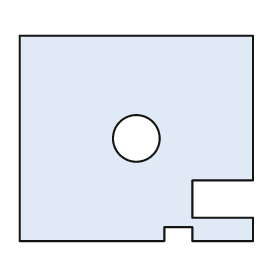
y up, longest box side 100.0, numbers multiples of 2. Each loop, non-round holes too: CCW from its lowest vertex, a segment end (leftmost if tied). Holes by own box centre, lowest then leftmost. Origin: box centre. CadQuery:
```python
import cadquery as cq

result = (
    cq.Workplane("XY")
    .moveTo(-50.0, -44.0)
    .lineTo(12.0, -44.0)
    .lineTo(12.0, -38.0)
    .lineTo(24.0, -38.0)
    .lineTo(24.0, -44.0)
    .lineTo(50.0, -44.0)
    .lineTo(50.0, -34.0)
    .lineTo(24.0, -34.0)
    .lineTo(24.0, -18.0)
    .lineTo(50.0, -18.0)
    .lineTo(50.0, 44.0)
    .lineTo(-50.0, 44.0)
    .close()
    .moveTo(0.0, 0.0)
    .circle(10.0)
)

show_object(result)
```